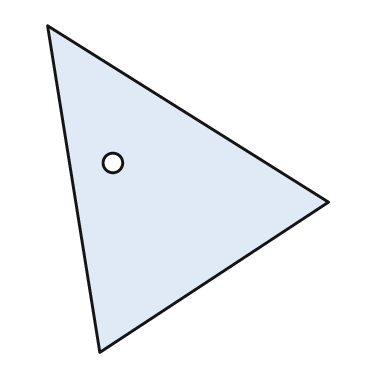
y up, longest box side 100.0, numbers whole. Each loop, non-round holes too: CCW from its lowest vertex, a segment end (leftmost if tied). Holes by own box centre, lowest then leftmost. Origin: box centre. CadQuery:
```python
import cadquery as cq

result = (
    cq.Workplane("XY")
    .moveTo(-27.0, -50.0)
    .lineTo(43.0, -4.0)
    .lineTo(-43.0, 50.0)
    .close()
    .moveTo(-23.0, 8.0)
    .circle(3.0)
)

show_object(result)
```